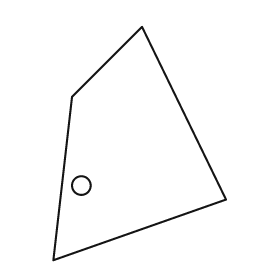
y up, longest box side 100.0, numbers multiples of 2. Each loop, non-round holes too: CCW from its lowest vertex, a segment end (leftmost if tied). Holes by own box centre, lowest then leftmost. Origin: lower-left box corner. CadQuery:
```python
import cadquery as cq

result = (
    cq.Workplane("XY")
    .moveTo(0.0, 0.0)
    .lineTo(74.0, 26.0)
    .lineTo(38.0, 100.0)
    .lineTo(8.0, 70.0)
    .close()
    .moveTo(12.0, 32.0)
    .circle(4.0)
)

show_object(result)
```